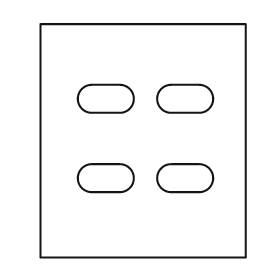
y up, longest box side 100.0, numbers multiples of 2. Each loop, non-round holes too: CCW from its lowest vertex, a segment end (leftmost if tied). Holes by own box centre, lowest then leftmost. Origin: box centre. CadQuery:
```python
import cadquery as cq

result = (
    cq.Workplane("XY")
    .moveTo(-44.0, -50.0)
    .lineTo(44.0, -50.0)
    .lineTo(44.0, 50.0)
    .lineTo(-44.0, 50.0)
    .close()
    .moveTo(-22.0, -22.0)
    .lineTo(-10.0, -22.0)
    .threePointArc((-4.0, -16.0), (-10.0, -10.0))
    .lineTo(-22.0, -10.0)
    .threePointArc((-28.0, -16.0), (-22.0, -22.0))
    .close()
    .moveTo(12.0, -22.0)
    .lineTo(24.0, -22.0)
    .threePointArc((30.0, -16.0), (24.0, -10.0))
    .lineTo(12.0, -10.0)
    .threePointArc((6.0, -16.0), (12.0, -22.0))
    .close()
    .moveTo(-22.0, 12.0)
    .lineTo(-10.0, 12.0)
    .threePointArc((-4.0, 18.0), (-10.0, 24.0))
    .lineTo(-22.0, 24.0)
    .threePointArc((-28.0, 18.0), (-22.0, 12.0))
    .close()
    .moveTo(12.0, 12.0)
    .lineTo(24.0, 12.0)
    .threePointArc((30.0, 18.0), (24.0, 24.0))
    .lineTo(12.0, 24.0)
    .threePointArc((6.0, 18.0), (12.0, 12.0))
    .close()
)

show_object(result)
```